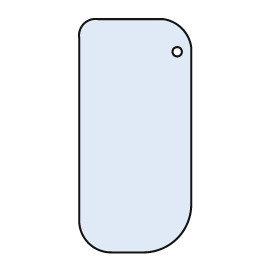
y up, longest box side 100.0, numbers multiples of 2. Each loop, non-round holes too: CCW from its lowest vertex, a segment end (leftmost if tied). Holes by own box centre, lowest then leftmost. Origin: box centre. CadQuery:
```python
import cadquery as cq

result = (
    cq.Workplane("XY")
    .moveTo(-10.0, -50.0)
    .lineTo(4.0, -50.0)
    .threePointArc((18.0, -44.0), (24.0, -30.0))
    .lineTo(24.0, 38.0)
    .threePointArc((20.0, 46.0), (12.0, 50.0))
    .lineTo(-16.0, 50.0)
    .threePointArc((-22.0, 48.0), (-24.0, 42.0))
    .lineTo(-24.0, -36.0)
    .threePointArc((-20.0, -46.0), (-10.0, -50.0))
    .close()
    .moveTo(18.0, 36.0)
    .circle(2.0)
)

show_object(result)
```